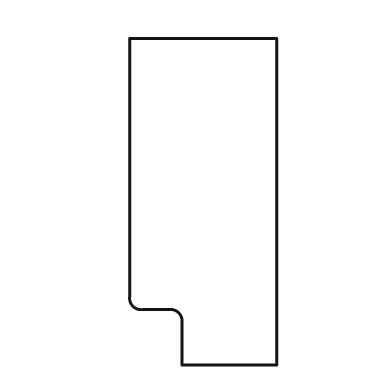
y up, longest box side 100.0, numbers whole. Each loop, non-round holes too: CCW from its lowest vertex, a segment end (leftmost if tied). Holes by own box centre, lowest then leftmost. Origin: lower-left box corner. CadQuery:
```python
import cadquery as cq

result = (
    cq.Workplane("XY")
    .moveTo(16.0, 0.0)
    .lineTo(45.0, 0.0)
    .lineTo(45.0, 100.0)
    .lineTo(0.0, 100.0)
    .lineTo(0.0, 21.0)
    .threePointArc((1.0, 18.0), (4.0, 17.0))
    .lineTo(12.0, 17.0)
    .threePointArc((15.0, 16.0), (16.0, 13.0))
    .close()
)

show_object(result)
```